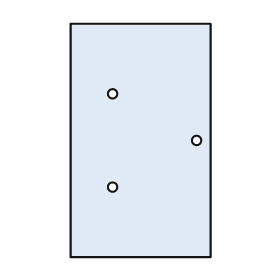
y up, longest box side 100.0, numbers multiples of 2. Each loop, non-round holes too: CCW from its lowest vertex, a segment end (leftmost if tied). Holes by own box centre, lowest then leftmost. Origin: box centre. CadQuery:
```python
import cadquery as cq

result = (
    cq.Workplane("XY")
    .moveTo(-30.0, -50.0)
    .lineTo(30.0, -50.0)
    .lineTo(30.0, 50.0)
    .lineTo(-30.0, 50.0)
    .close()
    .moveTo(-12.0, -20.0)
    .circle(2.0)
    .moveTo(24.0, 0.0)
    .circle(2.0)
    .moveTo(-12.0, 20.0)
    .circle(2.0)
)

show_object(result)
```